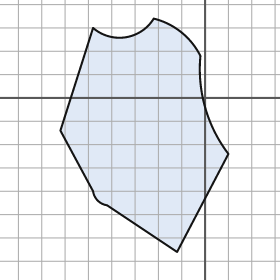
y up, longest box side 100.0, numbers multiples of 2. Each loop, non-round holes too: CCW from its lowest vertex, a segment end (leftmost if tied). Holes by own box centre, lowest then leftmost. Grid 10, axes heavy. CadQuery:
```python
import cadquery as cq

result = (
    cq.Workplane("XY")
    .moveTo(-12.0, -66.0)
    .lineTo(10.0, -24.0)
    .threePointArc((0.0, -4.0), (-2.0, 18.0))
    .threePointArc((-10.0, 28.0), (-22.0, 34.0))
    .threePointArc((-34.0, 26.0), (-48.0, 30.0))
    .lineTo(-62.0, -14.0)
    .lineTo(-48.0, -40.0)
    .threePointArc((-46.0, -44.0), (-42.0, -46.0))
    .close()
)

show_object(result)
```